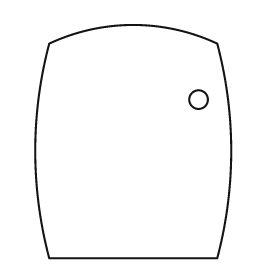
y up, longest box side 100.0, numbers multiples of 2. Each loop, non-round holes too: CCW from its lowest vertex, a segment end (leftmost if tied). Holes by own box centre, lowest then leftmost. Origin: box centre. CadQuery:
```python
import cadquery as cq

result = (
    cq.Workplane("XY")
    .moveTo(-36.0, -50.0)
    .lineTo(36.0, -50.0)
    .threePointArc((42.0, -4.0), (36.0, 42.0))
    .threePointArc((0.0, 50.0), (-36.0, 42.0))
    .threePointArc((-42.0, -4.0), (-36.0, -50.0))
    .close()
    .moveTo(28.0, 18.0)
    .circle(4.0)
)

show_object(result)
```